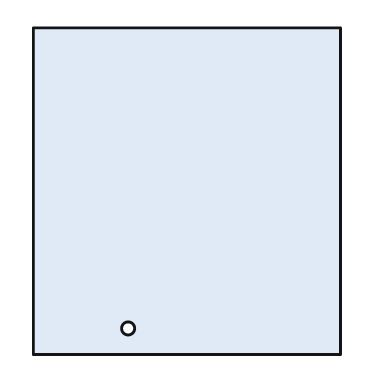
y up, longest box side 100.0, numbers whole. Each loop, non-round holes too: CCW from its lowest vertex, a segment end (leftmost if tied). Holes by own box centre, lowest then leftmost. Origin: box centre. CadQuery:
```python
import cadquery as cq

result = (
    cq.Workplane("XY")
    .moveTo(-47.0, -50.0)
    .lineTo(47.0, -50.0)
    .lineTo(47.0, 50.0)
    .lineTo(-47.0, 50.0)
    .close()
    .moveTo(-18.0, -42.0)
    .circle(2.0)
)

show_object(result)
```